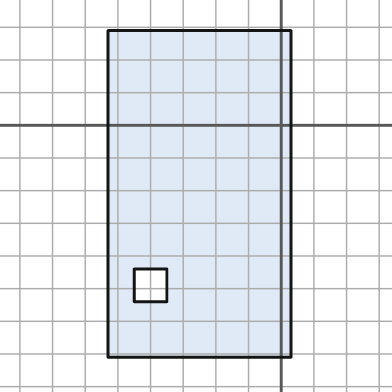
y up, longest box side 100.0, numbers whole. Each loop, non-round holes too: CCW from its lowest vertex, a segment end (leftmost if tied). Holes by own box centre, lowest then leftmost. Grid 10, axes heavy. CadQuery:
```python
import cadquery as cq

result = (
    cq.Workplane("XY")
    .moveTo(-53.0, -71.0)
    .lineTo(3.0, -71.0)
    .lineTo(3.0, 29.0)
    .lineTo(-53.0, 29.0)
    .close()
    .moveTo(-45.0, -54.0)
    .lineTo(-35.0, -54.0)
    .lineTo(-35.0, -44.0)
    .lineTo(-45.0, -44.0)
    .close()
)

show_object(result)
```